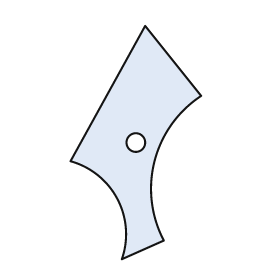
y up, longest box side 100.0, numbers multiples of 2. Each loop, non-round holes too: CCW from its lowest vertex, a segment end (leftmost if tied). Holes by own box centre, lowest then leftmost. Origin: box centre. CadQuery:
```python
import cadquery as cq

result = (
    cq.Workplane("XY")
    .moveTo(-6.0, -50.0)
    .lineTo(12.0, -42.0)
    .threePointArc((8.0, -8.0), (28.0, 20.0))
    .lineTo(4.0, 50.0)
    .lineTo(-28.0, -8.0)
    .threePointArc((-8.0, -24.0), (-6.0, -50.0))
    .close()
    .moveTo(0.0, 0.0)
    .circle(4.0)
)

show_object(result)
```